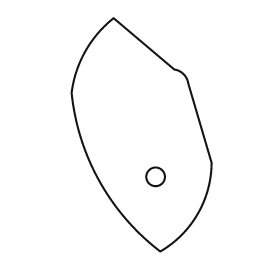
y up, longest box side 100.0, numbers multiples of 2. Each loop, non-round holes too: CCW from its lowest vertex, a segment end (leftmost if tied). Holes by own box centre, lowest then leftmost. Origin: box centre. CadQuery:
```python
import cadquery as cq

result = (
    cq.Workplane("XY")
    .moveTo(8.0, -50.0)
    .threePointArc((24.0, -34.0), (30.0, -12.0))
    .lineTo(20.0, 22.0)
    .threePointArc((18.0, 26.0), (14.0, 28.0))
    .lineTo(-12.0, 50.0)
    .threePointArc((-24.0, 36.0), (-30.0, 18.0))
    .threePointArc((-18.0, -20.0), (8.0, -50.0))
    .close()
    .moveTo(6.0, -18.0)
    .circle(4.0)
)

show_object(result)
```